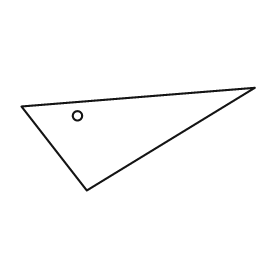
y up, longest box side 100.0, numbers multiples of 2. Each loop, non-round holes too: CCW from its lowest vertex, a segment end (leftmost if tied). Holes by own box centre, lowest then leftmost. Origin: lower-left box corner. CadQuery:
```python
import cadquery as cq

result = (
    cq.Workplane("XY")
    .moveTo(28.0, 0.0)
    .lineTo(100.0, 44.0)
    .lineTo(0.0, 36.0)
    .close()
    .moveTo(24.0, 32.0)
    .circle(2.0)
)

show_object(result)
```